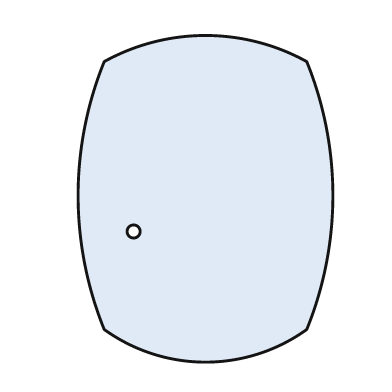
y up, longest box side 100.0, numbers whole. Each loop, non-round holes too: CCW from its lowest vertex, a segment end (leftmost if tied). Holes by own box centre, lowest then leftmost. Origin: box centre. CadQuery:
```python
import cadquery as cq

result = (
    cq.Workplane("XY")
    .moveTo(-31.0, -40.0)
    .threePointArc((0.0, -50.0), (31.0, -40.0))
    .threePointArc((39.0, 1.0), (31.0, 42.0))
    .threePointArc((0.0, 50.0), (-31.0, 42.0))
    .threePointArc((-39.0, 1.0), (-31.0, -40.0))
    .close()
    .moveTo(-22.0, -10.0)
    .circle(2.0)
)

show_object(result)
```